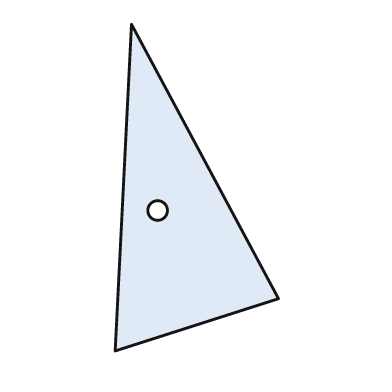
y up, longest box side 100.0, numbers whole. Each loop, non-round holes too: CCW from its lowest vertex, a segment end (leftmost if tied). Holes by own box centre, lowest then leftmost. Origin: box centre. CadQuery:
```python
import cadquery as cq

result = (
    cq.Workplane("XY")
    .moveTo(-25.0, -50.0)
    .lineTo(25.0, -34.0)
    .lineTo(-20.0, 50.0)
    .close()
    .moveTo(-12.0, -7.0)
    .circle(3.0)
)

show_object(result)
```